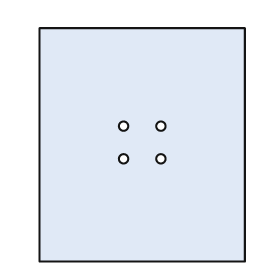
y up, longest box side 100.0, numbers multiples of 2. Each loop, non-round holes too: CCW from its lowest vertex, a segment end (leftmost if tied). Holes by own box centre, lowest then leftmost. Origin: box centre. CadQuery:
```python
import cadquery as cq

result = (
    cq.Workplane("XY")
    .moveTo(-44.0, -50.0)
    .lineTo(44.0, -50.0)
    .lineTo(44.0, 50.0)
    .lineTo(-44.0, 50.0)
    .close()
    .moveTo(-8.0, -6.0)
    .circle(2.0)
    .moveTo(8.0, -6.0)
    .circle(2.0)
    .moveTo(-8.0, 8.0)
    .circle(2.0)
    .moveTo(8.0, 8.0)
    .circle(2.0)
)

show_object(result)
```